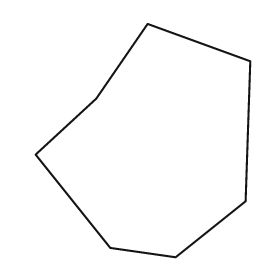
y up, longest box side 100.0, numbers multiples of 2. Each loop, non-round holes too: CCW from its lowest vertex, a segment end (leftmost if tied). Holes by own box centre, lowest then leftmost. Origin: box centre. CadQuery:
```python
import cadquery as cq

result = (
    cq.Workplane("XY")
    .moveTo(14.0, -50.0)
    .lineTo(44.0, -26.0)
    .lineTo(46.0, 34.0)
    .lineTo(2.0, 50.0)
    .lineTo(-20.0, 18.0)
    .lineTo(-46.0, -6.0)
    .lineTo(-14.0, -46.0)
    .close()
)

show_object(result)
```